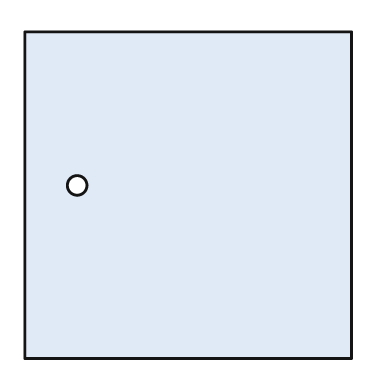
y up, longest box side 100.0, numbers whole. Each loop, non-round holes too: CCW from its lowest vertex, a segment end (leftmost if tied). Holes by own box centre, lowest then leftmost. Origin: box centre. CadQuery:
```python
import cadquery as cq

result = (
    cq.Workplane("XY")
    .moveTo(-50.0, -50.0)
    .lineTo(50.0, -50.0)
    .lineTo(50.0, 50.0)
    .lineTo(-50.0, 50.0)
    .close()
    .moveTo(-34.0, 3.0)
    .circle(3.0)
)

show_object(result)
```